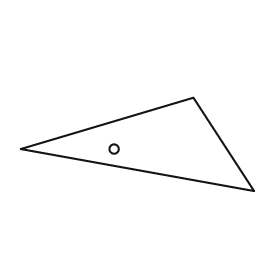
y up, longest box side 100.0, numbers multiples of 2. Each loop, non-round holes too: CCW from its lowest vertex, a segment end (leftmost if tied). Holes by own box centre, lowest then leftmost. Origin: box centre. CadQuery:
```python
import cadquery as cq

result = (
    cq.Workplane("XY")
    .moveTo(50.0, -20.0)
    .lineTo(24.0, 20.0)
    .lineTo(-50.0, -2.0)
    .close()
    .moveTo(-10.0, -2.0)
    .circle(2.0)
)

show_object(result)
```